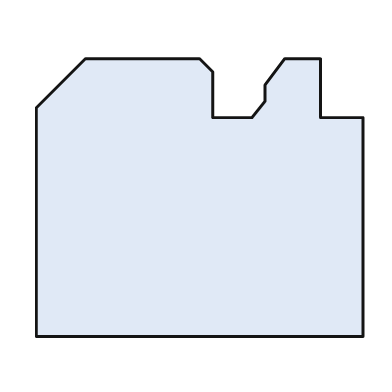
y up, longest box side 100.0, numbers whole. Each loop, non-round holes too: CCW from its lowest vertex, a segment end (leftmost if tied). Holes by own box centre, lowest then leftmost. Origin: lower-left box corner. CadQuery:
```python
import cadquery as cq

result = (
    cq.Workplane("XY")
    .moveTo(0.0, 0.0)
    .lineTo(100.0, 0.0)
    .lineTo(100.0, 67.0)
    .lineTo(87.0, 67.0)
    .lineTo(87.0, 85.0)
    .lineTo(76.0, 85.0)
    .lineTo(70.0, 77.0)
    .lineTo(70.0, 72.0)
    .lineTo(66.0, 67.0)
    .lineTo(54.0, 67.0)
    .lineTo(54.0, 81.0)
    .lineTo(50.0, 85.0)
    .lineTo(15.0, 85.0)
    .lineTo(0.0, 70.0)
    .close()
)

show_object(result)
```